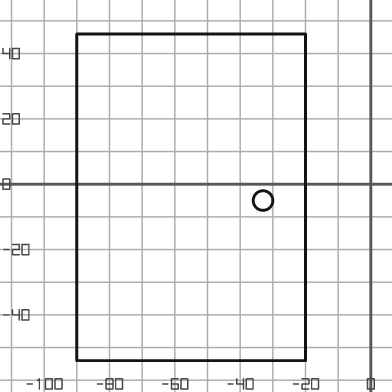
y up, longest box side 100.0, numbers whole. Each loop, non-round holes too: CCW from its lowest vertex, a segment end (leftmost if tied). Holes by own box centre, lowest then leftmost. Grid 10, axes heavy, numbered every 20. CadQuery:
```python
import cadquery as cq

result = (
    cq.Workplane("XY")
    .moveTo(-90.0, -54.0)
    .lineTo(-20.0, -54.0)
    .lineTo(-20.0, 46.0)
    .lineTo(-90.0, 46.0)
    .close()
    .moveTo(-33.0, -5.0)
    .circle(3.0)
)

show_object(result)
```